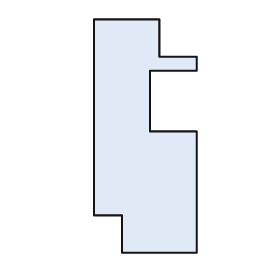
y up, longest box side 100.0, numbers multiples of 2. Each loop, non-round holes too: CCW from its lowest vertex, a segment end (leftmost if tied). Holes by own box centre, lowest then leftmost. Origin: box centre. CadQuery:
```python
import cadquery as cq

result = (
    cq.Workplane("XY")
    .moveTo(-10.0, -50.0)
    .lineTo(22.0, -50.0)
    .lineTo(22.0, 2.0)
    .lineTo(2.0, 2.0)
    .lineTo(2.0, 28.0)
    .lineTo(22.0, 28.0)
    .lineTo(22.0, 34.0)
    .lineTo(6.0, 34.0)
    .lineTo(6.0, 50.0)
    .lineTo(-22.0, 50.0)
    .lineTo(-22.0, -34.0)
    .lineTo(-10.0, -34.0)
    .close()
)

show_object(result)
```